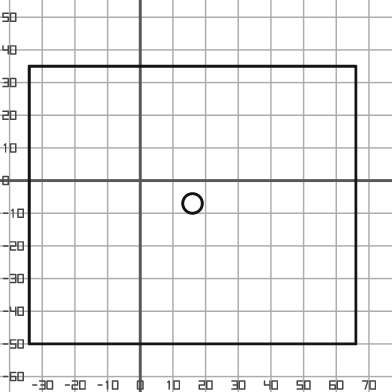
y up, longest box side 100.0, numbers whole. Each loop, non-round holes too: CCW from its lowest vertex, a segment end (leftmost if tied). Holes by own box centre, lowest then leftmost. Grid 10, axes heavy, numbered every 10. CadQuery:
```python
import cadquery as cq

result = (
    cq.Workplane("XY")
    .moveTo(-34.0, -50.0)
    .lineTo(66.0, -50.0)
    .lineTo(66.0, 35.0)
    .lineTo(-34.0, 35.0)
    .close()
    .moveTo(16.0, -7.0)
    .circle(3.0)
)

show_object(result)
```